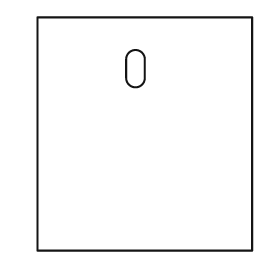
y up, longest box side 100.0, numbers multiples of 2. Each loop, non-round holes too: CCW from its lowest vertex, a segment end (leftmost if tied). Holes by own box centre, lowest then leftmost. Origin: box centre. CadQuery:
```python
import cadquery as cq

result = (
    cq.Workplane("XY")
    .moveTo(-46.0, -50.0)
    .lineTo(46.0, -50.0)
    .lineTo(46.0, 50.0)
    .lineTo(-46.0, 50.0)
    .close()
    .moveTo(-8.0, 24.0)
    .threePointArc((-4.0, 20.0), (0.0, 24.0))
    .lineTo(0.0, 32.0)
    .threePointArc((-4.0, 36.0), (-8.0, 32.0))
    .close()
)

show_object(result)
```